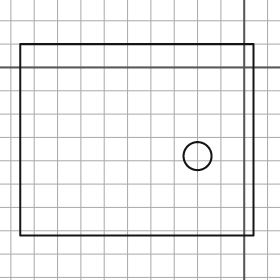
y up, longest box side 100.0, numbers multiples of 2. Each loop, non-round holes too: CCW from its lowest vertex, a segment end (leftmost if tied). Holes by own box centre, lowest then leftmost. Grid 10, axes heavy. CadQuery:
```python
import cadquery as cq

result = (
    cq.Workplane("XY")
    .moveTo(-96.0, -72.0)
    .lineTo(4.0, -72.0)
    .lineTo(4.0, 10.0)
    .lineTo(-96.0, 10.0)
    .close()
    .moveTo(-20.0, -38.0)
    .circle(6.0)
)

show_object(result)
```